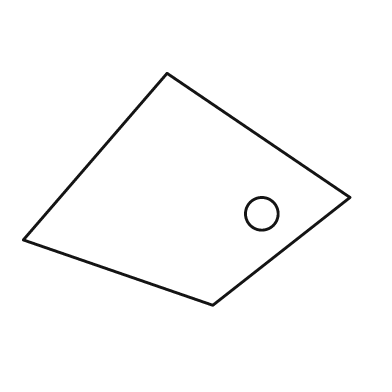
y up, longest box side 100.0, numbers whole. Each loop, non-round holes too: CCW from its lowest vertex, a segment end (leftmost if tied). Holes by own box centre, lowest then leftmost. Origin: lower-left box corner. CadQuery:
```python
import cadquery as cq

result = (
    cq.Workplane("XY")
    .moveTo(58.0, 0.0)
    .lineTo(100.0, 33.0)
    .lineTo(44.0, 71.0)
    .lineTo(0.0, 20.0)
    .close()
    .moveTo(73.0, 28.0)
    .circle(5.0)
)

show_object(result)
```